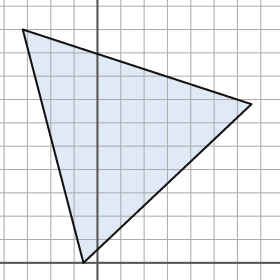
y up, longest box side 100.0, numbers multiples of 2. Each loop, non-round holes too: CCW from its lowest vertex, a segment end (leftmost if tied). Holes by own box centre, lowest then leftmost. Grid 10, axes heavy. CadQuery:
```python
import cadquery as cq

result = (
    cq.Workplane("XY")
    .moveTo(-6.0, 0.0)
    .lineTo(66.0, 68.0)
    .lineTo(-32.0, 100.0)
    .close()
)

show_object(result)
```